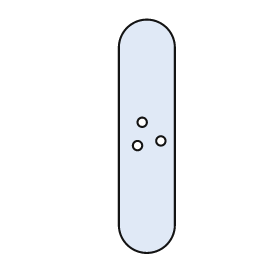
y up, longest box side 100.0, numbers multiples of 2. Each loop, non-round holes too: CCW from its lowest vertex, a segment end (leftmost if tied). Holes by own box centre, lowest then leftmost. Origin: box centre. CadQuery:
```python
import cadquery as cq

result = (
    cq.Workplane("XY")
    .moveTo(-12.0, -38.0)
    .threePointArc((0.0, -50.0), (12.0, -38.0))
    .lineTo(12.0, 38.0)
    .threePointArc((0.0, 50.0), (-12.0, 38.0))
    .close()
    .moveTo(-4.0, -4.0)
    .circle(2.0)
    .moveTo(6.0, -2.0)
    .circle(2.0)
    .moveTo(-2.0, 6.0)
    .circle(2.0)
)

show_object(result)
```